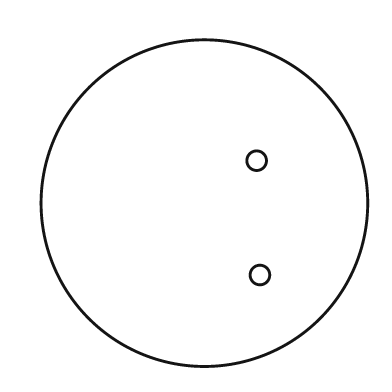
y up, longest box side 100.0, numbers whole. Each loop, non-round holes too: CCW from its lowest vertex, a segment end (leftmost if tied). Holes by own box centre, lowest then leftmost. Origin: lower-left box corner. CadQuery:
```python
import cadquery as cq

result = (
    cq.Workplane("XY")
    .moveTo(50.0, 50.0)
    .circle(50.0)
    .moveTo(67.0, 28.0)
    .circle(3.0)
    .moveTo(66.0, 63.0)
    .circle(3.0)
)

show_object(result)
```